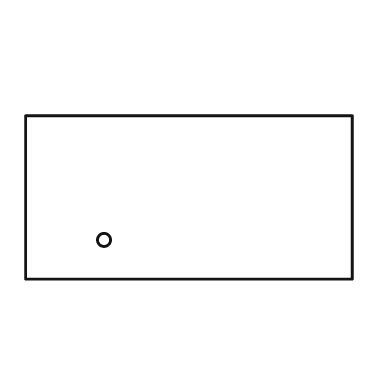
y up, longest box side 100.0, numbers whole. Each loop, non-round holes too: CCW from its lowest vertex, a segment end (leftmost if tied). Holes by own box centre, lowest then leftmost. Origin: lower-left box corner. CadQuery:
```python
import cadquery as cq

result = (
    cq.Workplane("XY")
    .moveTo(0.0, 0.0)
    .lineTo(100.0, 0.0)
    .lineTo(100.0, 50.0)
    .lineTo(0.0, 50.0)
    .close()
    .moveTo(24.0, 12.0)
    .circle(2.0)
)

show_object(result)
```